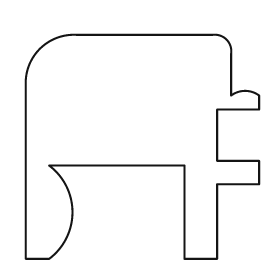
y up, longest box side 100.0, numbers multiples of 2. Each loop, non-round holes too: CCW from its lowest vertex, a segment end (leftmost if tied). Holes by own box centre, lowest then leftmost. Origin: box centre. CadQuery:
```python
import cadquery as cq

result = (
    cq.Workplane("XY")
    .moveTo(-50.0, -48.0)
    .lineTo(-40.0, -48.0)
    .threePointArc((-30.0, -28.0), (-40.0, -8.0))
    .lineTo(18.0, -8.0)
    .lineTo(18.0, -48.0)
    .lineTo(32.0, -48.0)
    .lineTo(32.0, -16.0)
    .lineTo(50.0, -16.0)
    .lineTo(50.0, -6.0)
    .lineTo(32.0, -6.0)
    .lineTo(32.0, 16.0)
    .lineTo(50.0, 16.0)
    .lineTo(50.0, 22.0)
    .threePointArc((44.0, 24.0), (38.0, 22.0))
    .lineTo(38.0, 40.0)
    .threePointArc((36.0, 46.0), (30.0, 48.0))
    .lineTo(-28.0, 48.0)
    .threePointArc((-44.0, 42.0), (-50.0, 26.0))
    .close()
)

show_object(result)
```